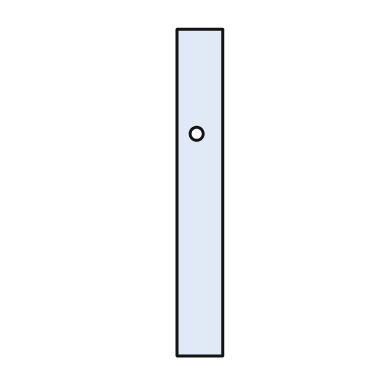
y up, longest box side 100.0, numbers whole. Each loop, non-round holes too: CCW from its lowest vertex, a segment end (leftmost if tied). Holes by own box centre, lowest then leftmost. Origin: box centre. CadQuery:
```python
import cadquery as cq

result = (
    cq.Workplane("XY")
    .moveTo(-7.0, -50.0)
    .lineTo(7.0, -50.0)
    .lineTo(7.0, 50.0)
    .lineTo(-7.0, 50.0)
    .close()
    .moveTo(-1.0, 18.0)
    .circle(2.0)
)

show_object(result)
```